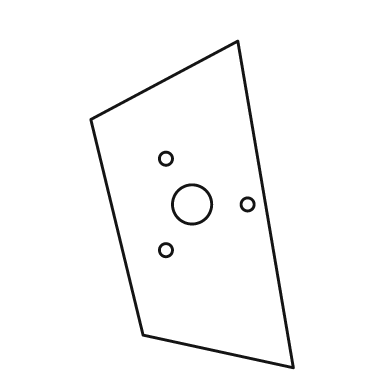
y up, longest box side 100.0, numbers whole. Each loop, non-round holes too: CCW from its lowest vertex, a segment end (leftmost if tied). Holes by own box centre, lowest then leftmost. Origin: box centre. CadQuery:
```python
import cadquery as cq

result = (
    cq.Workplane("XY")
    .moveTo(31.0, -50.0)
    .lineTo(14.0, 50.0)
    .lineTo(-31.0, 26.0)
    .lineTo(-15.0, -40.0)
    .close()
    .moveTo(-8.0, -14.0)
    .circle(2.0)
    .moveTo(0.0, 0.0)
    .circle(6.0)
    .moveTo(17.0, 0.0)
    .circle(2.0)
    .moveTo(-8.0, 14.0)
    .circle(2.0)
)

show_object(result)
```